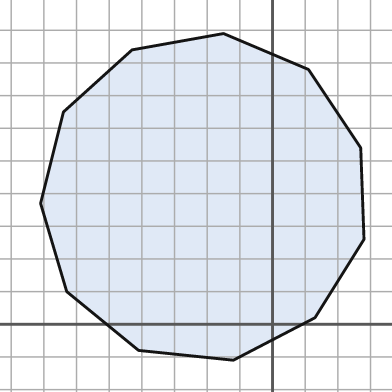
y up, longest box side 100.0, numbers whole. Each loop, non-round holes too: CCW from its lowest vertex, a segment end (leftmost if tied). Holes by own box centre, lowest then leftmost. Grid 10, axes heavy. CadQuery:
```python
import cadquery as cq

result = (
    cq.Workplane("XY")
    .moveTo(-12.0, -11.0)
    .lineTo(13.0, 2.0)
    .lineTo(28.0, 26.0)
    .lineTo(27.0, 54.0)
    .lineTo(11.0, 78.0)
    .lineTo(-15.0, 89.0)
    .lineTo(-43.0, 84.0)
    .lineTo(-64.0, 65.0)
    .lineTo(-71.0, 37.0)
    .lineTo(-63.0, 10.0)
    .lineTo(-41.0, -8.0)
    .close()
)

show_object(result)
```